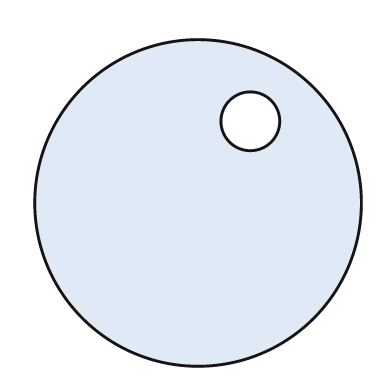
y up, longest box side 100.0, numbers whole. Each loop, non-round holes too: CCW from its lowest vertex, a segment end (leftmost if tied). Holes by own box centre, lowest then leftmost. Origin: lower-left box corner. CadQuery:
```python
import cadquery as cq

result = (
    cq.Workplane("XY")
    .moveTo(50.0, 50.0)
    .circle(50.0)
    .moveTo(66.0, 75.0)
    .circle(9.0)
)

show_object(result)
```